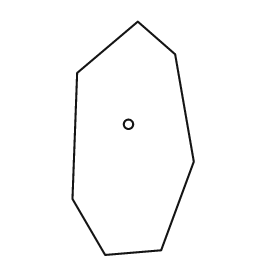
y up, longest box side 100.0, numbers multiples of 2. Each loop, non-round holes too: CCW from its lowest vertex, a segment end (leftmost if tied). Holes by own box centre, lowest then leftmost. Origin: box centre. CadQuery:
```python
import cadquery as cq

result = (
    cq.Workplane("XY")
    .moveTo(-12.0, -50.0)
    .lineTo(12.0, -48.0)
    .lineTo(26.0, -10.0)
    .lineTo(18.0, 36.0)
    .lineTo(2.0, 50.0)
    .lineTo(-24.0, 28.0)
    .lineTo(-26.0, -26.0)
    .close()
    .moveTo(-2.0, 6.0)
    .circle(2.0)
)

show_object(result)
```